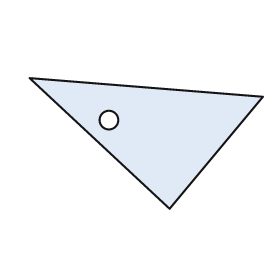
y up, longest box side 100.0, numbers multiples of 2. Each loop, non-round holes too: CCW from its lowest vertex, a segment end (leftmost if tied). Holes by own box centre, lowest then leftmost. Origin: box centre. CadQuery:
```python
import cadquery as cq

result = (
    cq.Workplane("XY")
    .moveTo(10.0, -28.0)
    .lineTo(50.0, 20.0)
    .lineTo(-50.0, 28.0)
    .close()
    .moveTo(-16.0, 10.0)
    .circle(4.0)
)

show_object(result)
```